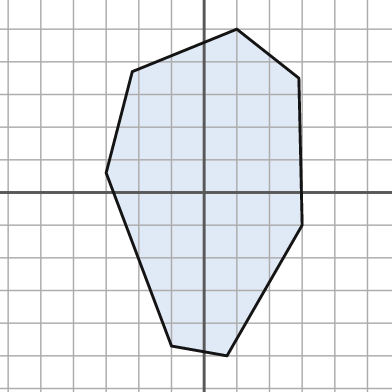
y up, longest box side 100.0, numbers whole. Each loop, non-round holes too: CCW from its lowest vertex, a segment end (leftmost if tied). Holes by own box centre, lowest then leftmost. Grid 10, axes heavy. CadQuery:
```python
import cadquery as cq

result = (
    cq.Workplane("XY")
    .moveTo(7.0, -50.0)
    .lineTo(30.0, -10.0)
    .lineTo(29.0, 35.0)
    .lineTo(10.0, 50.0)
    .lineTo(-22.0, 37.0)
    .lineTo(-30.0, 6.0)
    .lineTo(-10.0, -47.0)
    .close()
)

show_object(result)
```